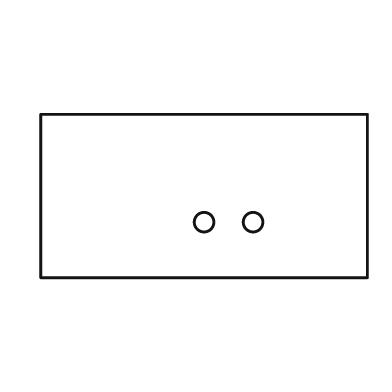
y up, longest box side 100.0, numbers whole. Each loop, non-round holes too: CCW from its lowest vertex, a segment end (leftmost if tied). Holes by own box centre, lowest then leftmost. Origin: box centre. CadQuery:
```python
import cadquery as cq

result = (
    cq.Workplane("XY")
    .moveTo(-50.0, -25.0)
    .lineTo(50.0, -25.0)
    .lineTo(50.0, 25.0)
    .lineTo(-50.0, 25.0)
    .close()
    .moveTo(0.0, -8.0)
    .circle(3.0)
    .moveTo(15.0, -8.0)
    .circle(3.0)
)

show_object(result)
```